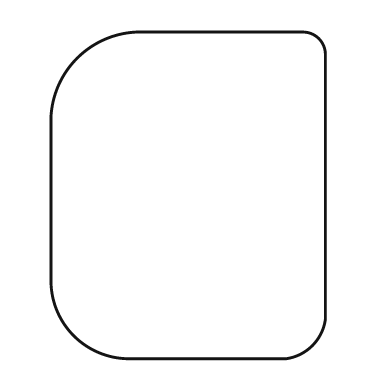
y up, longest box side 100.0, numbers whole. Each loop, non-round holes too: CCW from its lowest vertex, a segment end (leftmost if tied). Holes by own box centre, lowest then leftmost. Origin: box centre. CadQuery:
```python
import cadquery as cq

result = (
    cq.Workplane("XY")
    .moveTo(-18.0, -50.0)
    .lineTo(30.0, -50.0)
    .threePointArc((38.0, -46.0), (42.0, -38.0))
    .lineTo(42.0, 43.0)
    .threePointArc((40.0, 48.0), (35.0, 50.0))
    .lineTo(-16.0, 50.0)
    .threePointArc((-34.0, 42.0), (-42.0, 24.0))
    .lineTo(-42.0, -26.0)
    .threePointArc((-35.0, -43.0), (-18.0, -50.0))
    .close()
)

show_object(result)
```